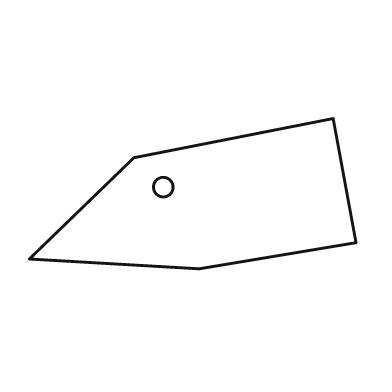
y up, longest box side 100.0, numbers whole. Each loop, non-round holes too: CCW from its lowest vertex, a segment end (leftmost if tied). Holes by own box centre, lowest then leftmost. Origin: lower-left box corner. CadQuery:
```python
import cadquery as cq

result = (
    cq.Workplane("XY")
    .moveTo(52.0, 0.0)
    .lineTo(100.0, 8.0)
    .lineTo(93.0, 46.0)
    .lineTo(32.0, 34.0)
    .lineTo(0.0, 3.0)
    .close()
    .moveTo(41.0, 25.0)
    .circle(3.0)
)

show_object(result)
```